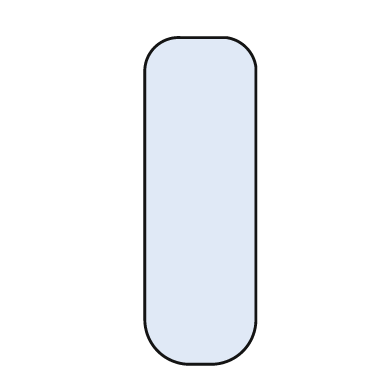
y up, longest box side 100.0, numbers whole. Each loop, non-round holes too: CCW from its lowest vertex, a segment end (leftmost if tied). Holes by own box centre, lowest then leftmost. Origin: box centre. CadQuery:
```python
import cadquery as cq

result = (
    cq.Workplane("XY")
    .moveTo(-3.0, -50.0)
    .lineTo(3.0, -50.0)
    .threePointArc((13.0, -46.0), (17.0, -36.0))
    .lineTo(17.0, 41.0)
    .threePointArc((14.0, 47.0), (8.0, 50.0))
    .lineTo(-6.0, 50.0)
    .threePointArc((-14.0, 47.0), (-17.0, 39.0))
    .lineTo(-17.0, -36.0)
    .threePointArc((-13.0, -46.0), (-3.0, -50.0))
    .close()
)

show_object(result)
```